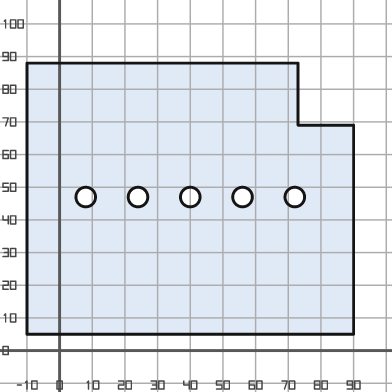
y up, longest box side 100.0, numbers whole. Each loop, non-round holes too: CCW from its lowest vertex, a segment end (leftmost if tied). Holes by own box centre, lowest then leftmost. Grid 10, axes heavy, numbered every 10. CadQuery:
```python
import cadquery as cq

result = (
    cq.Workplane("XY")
    .moveTo(-10.0, 5.0)
    .lineTo(90.0, 5.0)
    .lineTo(90.0, 69.0)
    .lineTo(73.0, 69.0)
    .lineTo(73.0, 88.0)
    .lineTo(-10.0, 88.0)
    .close()
    .moveTo(8.0, 47.0)
    .circle(3.0)
    .moveTo(24.0, 47.0)
    .circle(3.0)
    .moveTo(40.0, 47.0)
    .circle(3.0)
    .moveTo(56.0, 47.0)
    .circle(3.0)
    .moveTo(72.0, 47.0)
    .circle(3.0)
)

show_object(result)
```